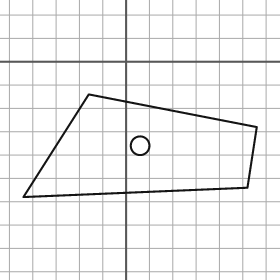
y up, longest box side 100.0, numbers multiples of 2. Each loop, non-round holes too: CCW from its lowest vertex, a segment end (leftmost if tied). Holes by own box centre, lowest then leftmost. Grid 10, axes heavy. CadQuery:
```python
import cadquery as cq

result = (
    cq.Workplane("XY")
    .moveTo(-44.0, -58.0)
    .lineTo(52.0, -54.0)
    .lineTo(56.0, -28.0)
    .lineTo(-16.0, -14.0)
    .close()
    .moveTo(6.0, -36.0)
    .circle(4.0)
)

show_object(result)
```